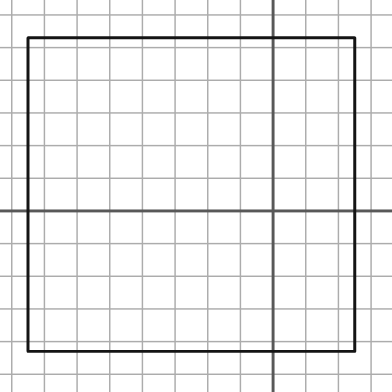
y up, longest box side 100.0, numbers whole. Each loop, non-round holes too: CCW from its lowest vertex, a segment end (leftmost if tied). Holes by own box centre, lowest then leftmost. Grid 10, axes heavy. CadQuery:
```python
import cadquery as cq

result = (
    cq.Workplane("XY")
    .moveTo(-75.0, -43.0)
    .lineTo(25.0, -43.0)
    .lineTo(25.0, 53.0)
    .lineTo(-75.0, 53.0)
    .close()
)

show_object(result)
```